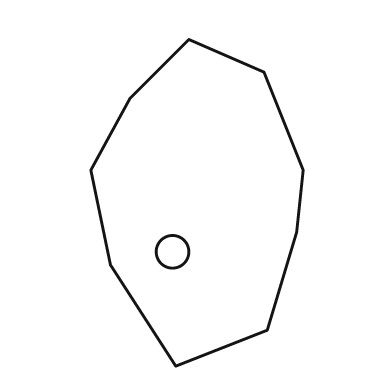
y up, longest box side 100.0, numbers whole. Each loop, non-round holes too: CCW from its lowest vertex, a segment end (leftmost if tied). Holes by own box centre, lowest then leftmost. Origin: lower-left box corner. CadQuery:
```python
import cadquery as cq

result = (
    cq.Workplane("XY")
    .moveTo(26.0, 0.0)
    .lineTo(54.0, 11.0)
    .lineTo(63.0, 41.0)
    .lineTo(65.0, 60.0)
    .lineTo(53.0, 90.0)
    .lineTo(30.0, 100.0)
    .lineTo(12.0, 82.0)
    .lineTo(0.0, 60.0)
    .lineTo(6.0, 31.0)
    .close()
    .moveTo(25.0, 35.0)
    .circle(5.0)
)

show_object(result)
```